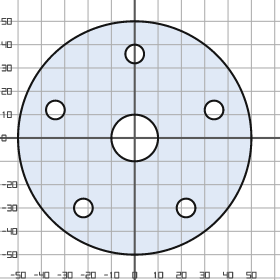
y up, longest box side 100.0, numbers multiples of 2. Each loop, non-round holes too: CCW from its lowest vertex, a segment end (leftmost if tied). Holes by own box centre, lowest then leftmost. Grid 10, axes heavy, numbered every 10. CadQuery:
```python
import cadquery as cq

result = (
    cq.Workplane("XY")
    .moveTo(0.0, 0.0)
    .circle(50.0)
    .moveTo(-22.0, -30.0)
    .circle(4.0)
    .moveTo(22.0, -30.0)
    .circle(4.0)
    .moveTo(0.0, 0.0)
    .circle(10.0)
    .moveTo(-34.0, 12.0)
    .circle(4.0)
    .moveTo(34.0, 12.0)
    .circle(4.0)
    .moveTo(0.0, 36.0)
    .circle(4.0)
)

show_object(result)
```